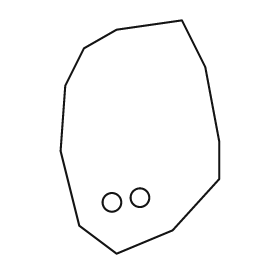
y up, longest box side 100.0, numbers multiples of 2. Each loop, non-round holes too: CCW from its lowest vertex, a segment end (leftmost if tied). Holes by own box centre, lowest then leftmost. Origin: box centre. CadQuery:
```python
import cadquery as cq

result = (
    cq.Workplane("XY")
    .moveTo(-10.0, -50.0)
    .lineTo(14.0, -40.0)
    .lineTo(34.0, -18.0)
    .lineTo(34.0, -2.0)
    .lineTo(28.0, 30.0)
    .lineTo(18.0, 50.0)
    .lineTo(-10.0, 46.0)
    .lineTo(-24.0, 38.0)
    .lineTo(-32.0, 22.0)
    .lineTo(-34.0, -6.0)
    .lineTo(-26.0, -38.0)
    .close()
    .moveTo(-12.0, -28.0)
    .circle(4.0)
    .moveTo(0.0, -26.0)
    .circle(4.0)
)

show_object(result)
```